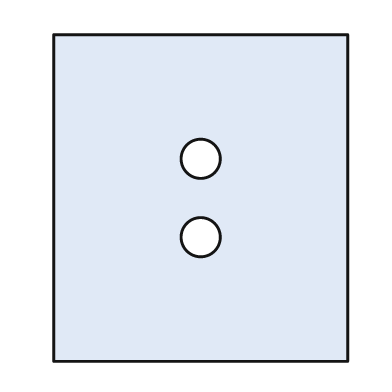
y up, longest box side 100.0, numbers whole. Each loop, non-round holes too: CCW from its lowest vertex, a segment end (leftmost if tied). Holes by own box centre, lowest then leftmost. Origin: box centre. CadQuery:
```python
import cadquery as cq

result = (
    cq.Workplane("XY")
    .moveTo(-45.0, -50.0)
    .lineTo(45.0, -50.0)
    .lineTo(45.0, 50.0)
    .lineTo(-45.0, 50.0)
    .close()
    .moveTo(0.0, -12.0)
    .circle(6.0)
    .moveTo(0.0, 12.0)
    .circle(6.0)
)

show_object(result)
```